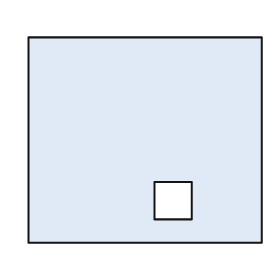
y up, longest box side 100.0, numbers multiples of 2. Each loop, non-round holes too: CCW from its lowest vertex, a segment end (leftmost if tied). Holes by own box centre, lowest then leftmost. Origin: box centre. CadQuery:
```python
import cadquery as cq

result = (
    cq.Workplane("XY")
    .moveTo(-50.0, -44.0)
    .lineTo(50.0, -44.0)
    .lineTo(50.0, 44.0)
    .lineTo(-50.0, 44.0)
    .close()
    .moveTo(4.0, -34.0)
    .lineTo(20.0, -34.0)
    .lineTo(20.0, -18.0)
    .lineTo(4.0, -18.0)
    .close()
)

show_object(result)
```